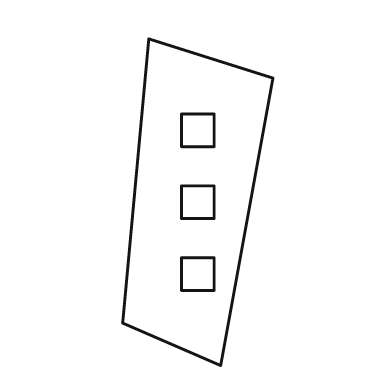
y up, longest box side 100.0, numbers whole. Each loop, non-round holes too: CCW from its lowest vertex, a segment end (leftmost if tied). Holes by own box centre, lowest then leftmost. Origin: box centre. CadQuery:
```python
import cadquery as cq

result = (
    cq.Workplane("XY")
    .moveTo(7.0, -50.0)
    .lineTo(23.0, 38.0)
    .lineTo(-15.0, 50.0)
    .lineTo(-23.0, -37.0)
    .close()
    .moveTo(-5.0, -27.0)
    .lineTo(5.0, -27.0)
    .lineTo(5.0, -17.0)
    .lineTo(-5.0, -17.0)
    .close()
    .moveTo(-5.0, -5.0)
    .lineTo(5.0, -5.0)
    .lineTo(5.0, 5.0)
    .lineTo(-5.0, 5.0)
    .close()
    .moveTo(-5.0, 17.0)
    .lineTo(5.0, 17.0)
    .lineTo(5.0, 27.0)
    .lineTo(-5.0, 27.0)
    .close()
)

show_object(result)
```